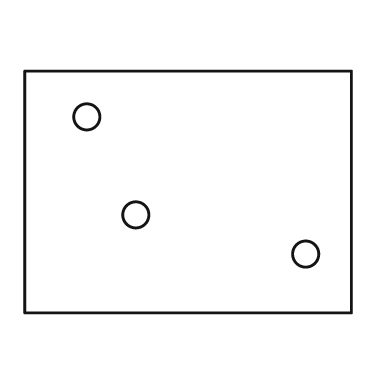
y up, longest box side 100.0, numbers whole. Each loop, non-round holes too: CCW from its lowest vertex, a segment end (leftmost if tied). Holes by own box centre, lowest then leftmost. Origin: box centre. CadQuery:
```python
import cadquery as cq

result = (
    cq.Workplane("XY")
    .moveTo(-50.0, -37.0)
    .lineTo(50.0, -37.0)
    .lineTo(50.0, 37.0)
    .lineTo(-50.0, 37.0)
    .close()
    .moveTo(36.0, -19.0)
    .circle(4.0)
    .moveTo(-16.0, -7.0)
    .circle(4.0)
    .moveTo(-31.0, 23.0)
    .circle(4.0)
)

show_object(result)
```